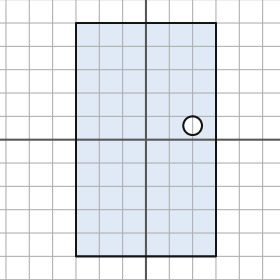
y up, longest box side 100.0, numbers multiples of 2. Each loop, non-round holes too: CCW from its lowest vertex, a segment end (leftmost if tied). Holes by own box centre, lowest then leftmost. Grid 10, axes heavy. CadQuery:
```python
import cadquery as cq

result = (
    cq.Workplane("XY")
    .moveTo(-30.0, -50.0)
    .lineTo(30.0, -50.0)
    .lineTo(30.0, 50.0)
    .lineTo(-30.0, 50.0)
    .close()
    .moveTo(20.0, 6.0)
    .circle(4.0)
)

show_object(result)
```